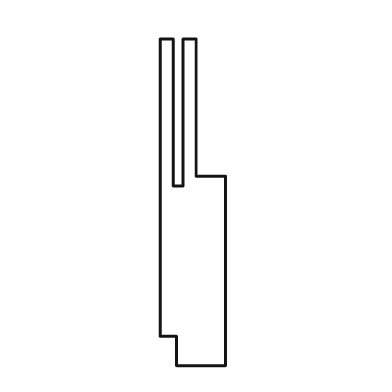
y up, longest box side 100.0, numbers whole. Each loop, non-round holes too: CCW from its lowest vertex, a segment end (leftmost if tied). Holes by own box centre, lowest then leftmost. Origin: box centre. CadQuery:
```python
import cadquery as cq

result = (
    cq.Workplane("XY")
    .moveTo(-5.0, -50.0)
    .lineTo(10.0, -50.0)
    .lineTo(10.0, 8.0)
    .lineTo(1.0, 8.0)
    .lineTo(1.0, 50.0)
    .lineTo(-3.0, 50.0)
    .lineTo(-3.0, 5.0)
    .lineTo(-6.0, 5.0)
    .lineTo(-6.0, 50.0)
    .lineTo(-10.0, 50.0)
    .lineTo(-10.0, -41.0)
    .lineTo(-5.0, -41.0)
    .close()
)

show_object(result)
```